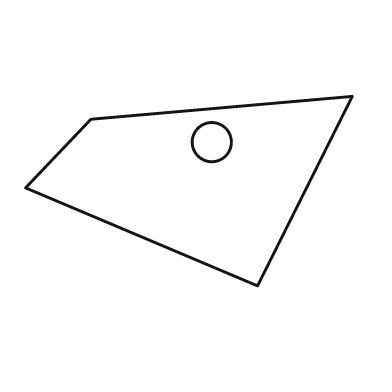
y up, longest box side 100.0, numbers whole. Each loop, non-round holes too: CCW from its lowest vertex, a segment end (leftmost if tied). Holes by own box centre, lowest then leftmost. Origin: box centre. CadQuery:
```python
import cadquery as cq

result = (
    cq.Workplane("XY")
    .moveTo(21.0, -29.0)
    .lineTo(50.0, 29.0)
    .lineTo(-30.0, 22.0)
    .lineTo(-50.0, 1.0)
    .close()
    .moveTo(7.0, 15.0)
    .circle(6.0)
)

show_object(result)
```